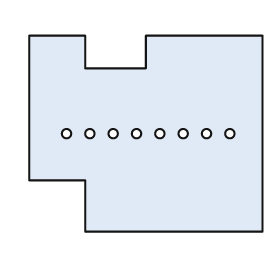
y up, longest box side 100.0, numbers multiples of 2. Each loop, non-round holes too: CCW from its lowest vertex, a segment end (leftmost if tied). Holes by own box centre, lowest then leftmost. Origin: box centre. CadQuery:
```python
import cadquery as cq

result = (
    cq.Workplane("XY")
    .moveTo(-26.0, -42.0)
    .lineTo(50.0, -42.0)
    .lineTo(50.0, 42.0)
    .lineTo(0.0, 42.0)
    .lineTo(0.0, 28.0)
    .lineTo(-26.0, 28.0)
    .lineTo(-26.0, 42.0)
    .lineTo(-50.0, 42.0)
    .lineTo(-50.0, -20.0)
    .lineTo(-26.0, -20.0)
    .close()
    .moveTo(-34.0, 0.0)
    .circle(2.0)
    .moveTo(-24.0, 0.0)
    .circle(2.0)
    .moveTo(-14.0, 0.0)
    .circle(2.0)
    .moveTo(-4.0, 0.0)
    .circle(2.0)
    .moveTo(6.0, 0.0)
    .circle(2.0)
    .moveTo(16.0, 0.0)
    .circle(2.0)
    .moveTo(26.0, 0.0)
    .circle(2.0)
    .moveTo(36.0, 0.0)
    .circle(2.0)
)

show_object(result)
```